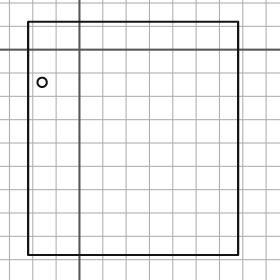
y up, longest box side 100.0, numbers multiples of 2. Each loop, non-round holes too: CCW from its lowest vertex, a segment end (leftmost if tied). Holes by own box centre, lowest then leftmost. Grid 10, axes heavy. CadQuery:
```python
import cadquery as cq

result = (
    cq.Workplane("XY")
    .moveTo(-22.0, -88.0)
    .lineTo(68.0, -88.0)
    .lineTo(68.0, 12.0)
    .lineTo(-22.0, 12.0)
    .close()
    .moveTo(-16.0, -14.0)
    .circle(2.0)
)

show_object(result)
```